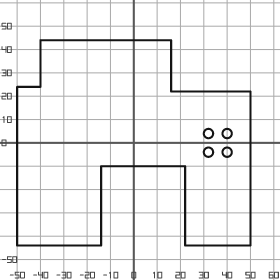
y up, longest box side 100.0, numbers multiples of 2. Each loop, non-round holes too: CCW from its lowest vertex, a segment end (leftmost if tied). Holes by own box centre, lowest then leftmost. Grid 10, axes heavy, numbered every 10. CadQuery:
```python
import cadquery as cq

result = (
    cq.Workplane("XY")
    .moveTo(-50.0, -44.0)
    .lineTo(-14.0, -44.0)
    .lineTo(-14.0, -10.0)
    .lineTo(22.0, -10.0)
    .lineTo(22.0, -44.0)
    .lineTo(50.0, -44.0)
    .lineTo(50.0, 22.0)
    .lineTo(16.0, 22.0)
    .lineTo(16.0, 44.0)
    .lineTo(-40.0, 44.0)
    .lineTo(-40.0, 24.0)
    .lineTo(-50.0, 24.0)
    .close()
    .moveTo(32.0, -4.0)
    .circle(2.0)
    .moveTo(40.0, -4.0)
    .circle(2.0)
    .moveTo(32.0, 4.0)
    .circle(2.0)
    .moveTo(40.0, 4.0)
    .circle(2.0)
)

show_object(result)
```